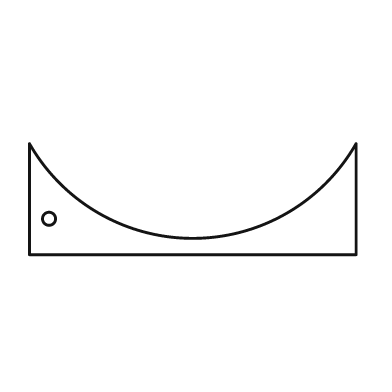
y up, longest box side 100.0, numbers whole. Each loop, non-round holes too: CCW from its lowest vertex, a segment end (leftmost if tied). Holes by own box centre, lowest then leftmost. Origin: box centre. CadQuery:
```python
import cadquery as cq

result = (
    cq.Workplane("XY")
    .moveTo(-50.0, -17.0)
    .lineTo(50.0, -17.0)
    .lineTo(50.0, 17.0)
    .threePointArc((0.0, -12.0), (-50.0, 17.0))
    .close()
    .moveTo(-44.0, -6.0)
    .circle(2.0)
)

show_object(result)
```